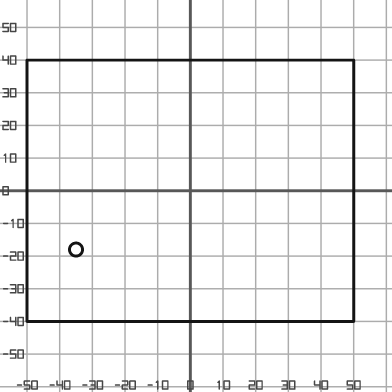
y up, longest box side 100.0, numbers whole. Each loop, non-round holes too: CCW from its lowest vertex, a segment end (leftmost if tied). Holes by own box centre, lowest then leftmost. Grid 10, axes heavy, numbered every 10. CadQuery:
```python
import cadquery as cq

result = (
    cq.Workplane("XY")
    .moveTo(-50.0, -40.0)
    .lineTo(50.0, -40.0)
    .lineTo(50.0, 40.0)
    .lineTo(-50.0, 40.0)
    .close()
    .moveTo(-35.0, -18.0)
    .circle(2.0)
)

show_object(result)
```